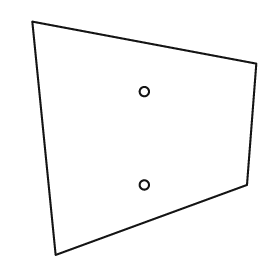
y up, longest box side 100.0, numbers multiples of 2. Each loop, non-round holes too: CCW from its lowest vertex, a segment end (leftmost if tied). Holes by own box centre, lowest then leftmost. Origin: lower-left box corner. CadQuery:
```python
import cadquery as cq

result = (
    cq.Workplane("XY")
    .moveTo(10.0, 0.0)
    .lineTo(92.0, 30.0)
    .lineTo(96.0, 82.0)
    .lineTo(0.0, 100.0)
    .close()
    .moveTo(48.0, 30.0)
    .circle(2.0)
    .moveTo(48.0, 70.0)
    .circle(2.0)
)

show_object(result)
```